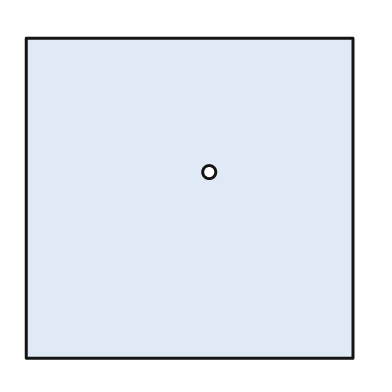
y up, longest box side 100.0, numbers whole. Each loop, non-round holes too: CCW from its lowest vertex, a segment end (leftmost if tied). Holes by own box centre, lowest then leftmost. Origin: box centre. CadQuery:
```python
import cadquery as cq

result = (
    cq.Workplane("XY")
    .moveTo(-50.0, -49.0)
    .lineTo(50.0, -49.0)
    .lineTo(50.0, 49.0)
    .lineTo(-50.0, 49.0)
    .close()
    .moveTo(6.0, 8.0)
    .circle(2.0)
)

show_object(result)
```